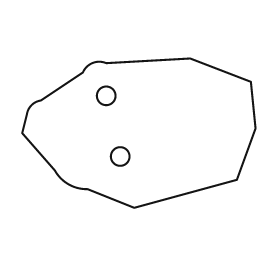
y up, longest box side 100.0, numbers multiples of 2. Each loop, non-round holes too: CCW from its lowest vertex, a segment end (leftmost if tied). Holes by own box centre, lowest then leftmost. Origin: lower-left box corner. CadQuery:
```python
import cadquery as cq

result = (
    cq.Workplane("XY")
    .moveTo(48.0, 0.0)
    .lineTo(92.0, 12.0)
    .lineTo(100.0, 34.0)
    .lineTo(98.0, 54.0)
    .lineTo(72.0, 64.0)
    .lineTo(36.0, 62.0)
    .threePointArc((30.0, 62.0), (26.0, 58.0))
    .lineTo(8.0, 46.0)
    .threePointArc((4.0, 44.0), (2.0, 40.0))
    .lineTo(0.0, 32.0)
    .lineTo(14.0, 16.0)
    .threePointArc((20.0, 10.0), (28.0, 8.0))
    .close()
    .moveTo(42.0, 22.0)
    .circle(4.0)
    .moveTo(36.0, 48.0)
    .circle(4.0)
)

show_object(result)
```